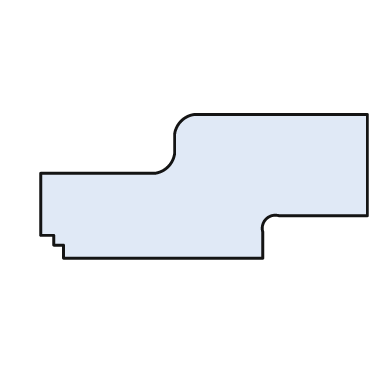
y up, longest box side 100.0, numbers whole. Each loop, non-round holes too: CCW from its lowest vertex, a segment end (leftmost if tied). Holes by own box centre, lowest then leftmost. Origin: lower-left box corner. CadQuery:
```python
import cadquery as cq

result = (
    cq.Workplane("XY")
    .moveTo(7.0, 0.0)
    .lineTo(68.0, 0.0)
    .lineTo(68.0, 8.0)
    .threePointArc((69.0, 12.0), (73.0, 13.0))
    .lineTo(100.0, 13.0)
    .lineTo(100.0, 44.0)
    .lineTo(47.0, 44.0)
    .threePointArc((43.0, 42.0), (41.0, 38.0))
    .lineTo(41.0, 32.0)
    .threePointArc((39.0, 28.0), (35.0, 26.0))
    .lineTo(0.0, 26.0)
    .lineTo(0.0, 7.0)
    .lineTo(4.0, 7.0)
    .lineTo(4.0, 4.0)
    .lineTo(7.0, 4.0)
    .close()
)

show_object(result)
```